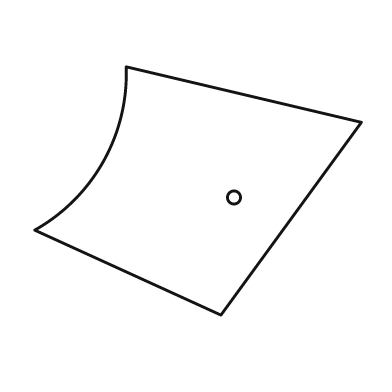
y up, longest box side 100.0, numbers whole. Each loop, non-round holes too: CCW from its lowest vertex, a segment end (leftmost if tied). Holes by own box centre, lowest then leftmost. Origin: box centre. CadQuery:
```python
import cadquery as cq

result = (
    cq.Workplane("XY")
    .moveTo(7.0, -38.0)
    .lineTo(50.0, 21.0)
    .lineTo(-22.0, 38.0)
    .threePointArc((-29.0, 9.0), (-50.0, -12.0))
    .close()
    .moveTo(11.0, -2.0)
    .circle(2.0)
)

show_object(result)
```